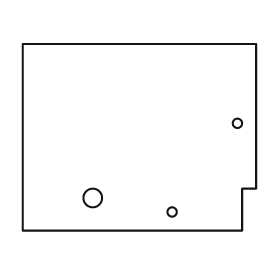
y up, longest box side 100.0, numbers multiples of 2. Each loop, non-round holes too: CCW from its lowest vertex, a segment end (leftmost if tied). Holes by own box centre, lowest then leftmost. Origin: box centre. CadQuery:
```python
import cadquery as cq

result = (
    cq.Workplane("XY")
    .moveTo(-50.0, -40.0)
    .lineTo(44.0, -40.0)
    .lineTo(44.0, -22.0)
    .lineTo(50.0, -22.0)
    .lineTo(50.0, 40.0)
    .lineTo(-50.0, 40.0)
    .close()
    .moveTo(14.0, -32.0)
    .circle(2.0)
    .moveTo(-20.0, -26.0)
    .circle(4.0)
    .moveTo(42.0, 6.0)
    .circle(2.0)
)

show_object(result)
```